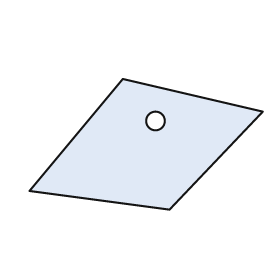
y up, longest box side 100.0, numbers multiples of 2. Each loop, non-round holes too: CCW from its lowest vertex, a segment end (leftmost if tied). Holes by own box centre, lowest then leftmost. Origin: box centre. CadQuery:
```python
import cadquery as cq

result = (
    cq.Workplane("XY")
    .moveTo(10.0, -28.0)
    .lineTo(50.0, 14.0)
    .lineTo(-10.0, 28.0)
    .lineTo(-50.0, -20.0)
    .close()
    .moveTo(4.0, 10.0)
    .circle(4.0)
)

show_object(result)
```